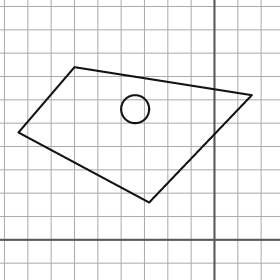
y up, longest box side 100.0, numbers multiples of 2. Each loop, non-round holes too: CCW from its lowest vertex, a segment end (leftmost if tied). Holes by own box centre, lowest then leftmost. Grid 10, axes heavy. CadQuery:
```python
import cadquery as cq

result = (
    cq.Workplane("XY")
    .moveTo(-28.0, 16.0)
    .lineTo(16.0, 62.0)
    .lineTo(-60.0, 74.0)
    .lineTo(-84.0, 46.0)
    .close()
    .moveTo(-34.0, 56.0)
    .circle(6.0)
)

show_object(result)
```